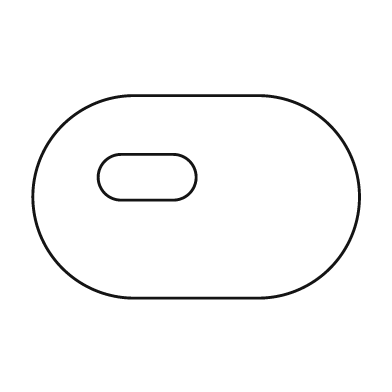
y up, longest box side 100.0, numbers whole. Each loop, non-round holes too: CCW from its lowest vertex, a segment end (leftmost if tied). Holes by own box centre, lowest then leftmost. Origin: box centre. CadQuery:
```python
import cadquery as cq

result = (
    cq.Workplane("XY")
    .moveTo(-19.0, -31.0)
    .lineTo(19.0, -31.0)
    .threePointArc((50.0, 0.0), (19.0, 31.0))
    .lineTo(-19.0, 31.0)
    .threePointArc((-50.0, 0.0), (-19.0, -31.0))
    .close()
    .moveTo(-23.0, -1.0)
    .lineTo(-7.0, -1.0)
    .threePointArc((0.0, 6.0), (-7.0, 13.0))
    .lineTo(-23.0, 13.0)
    .threePointArc((-30.0, 6.0), (-23.0, -1.0))
    .close()
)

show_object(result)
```